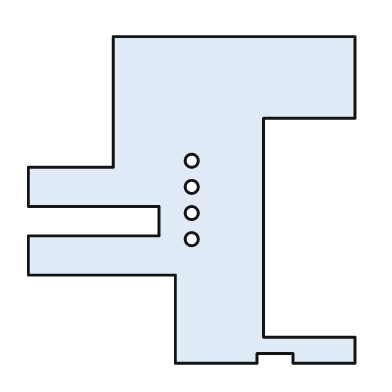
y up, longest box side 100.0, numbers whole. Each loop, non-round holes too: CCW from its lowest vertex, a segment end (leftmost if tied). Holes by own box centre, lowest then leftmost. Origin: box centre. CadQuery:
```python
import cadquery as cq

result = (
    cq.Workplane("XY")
    .moveTo(-5.0, -50.0)
    .lineTo(20.0, -50.0)
    .lineTo(20.0, -47.0)
    .lineTo(31.0, -47.0)
    .lineTo(31.0, -50.0)
    .lineTo(50.0, -50.0)
    .lineTo(50.0, -42.0)
    .lineTo(22.0, -42.0)
    .lineTo(22.0, 25.0)
    .lineTo(50.0, 25.0)
    .lineTo(50.0, 50.0)
    .lineTo(-24.0, 50.0)
    .lineTo(-24.0, 10.0)
    .lineTo(-50.0, 10.0)
    .lineTo(-50.0, -2.0)
    .lineTo(-10.0, -2.0)
    .lineTo(-10.0, -11.0)
    .lineTo(-50.0, -11.0)
    .lineTo(-50.0, -23.0)
    .lineTo(-5.0, -23.0)
    .close()
    .moveTo(0.0, -12.0)
    .circle(2.0)
    .moveTo(0.0, -4.0)
    .circle(2.0)
    .moveTo(0.0, 4.0)
    .circle(2.0)
    .moveTo(0.0, 12.0)
    .circle(2.0)
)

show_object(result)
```